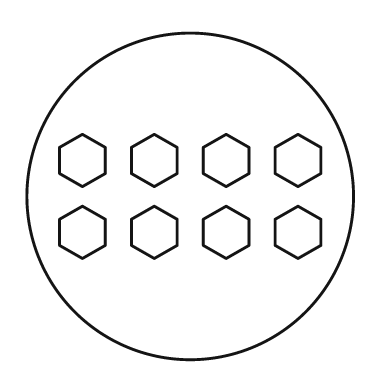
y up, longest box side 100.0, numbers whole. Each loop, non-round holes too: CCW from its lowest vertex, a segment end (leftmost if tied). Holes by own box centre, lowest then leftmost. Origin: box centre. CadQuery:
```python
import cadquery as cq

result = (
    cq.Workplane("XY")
    .moveTo(0.0, 0.0)
    .circle(50.0)
    .moveTo(-33.0, -19.0)
    .lineTo(-26.0, -15.0)
    .lineTo(-26.0, -7.0)
    .lineTo(-33.0, -3.0)
    .lineTo(-40.0, -7.0)
    .lineTo(-40.0, -15.0)
    .close()
    .moveTo(-11.0, -19.0)
    .lineTo(-4.0, -15.0)
    .lineTo(-4.0, -7.0)
    .lineTo(-11.0, -3.0)
    .lineTo(-18.0, -7.0)
    .lineTo(-18.0, -15.0)
    .close()
    .moveTo(11.0, -19.0)
    .lineTo(18.0, -15.0)
    .lineTo(18.0, -7.0)
    .lineTo(11.0, -3.0)
    .lineTo(4.0, -7.0)
    .lineTo(4.0, -15.0)
    .close()
    .moveTo(33.0, -19.0)
    .lineTo(40.0, -15.0)
    .lineTo(40.0, -7.0)
    .lineTo(33.0, -3.0)
    .lineTo(26.0, -7.0)
    .lineTo(26.0, -15.0)
    .close()
    .moveTo(-33.0, 3.0)
    .lineTo(-26.0, 7.0)
    .lineTo(-26.0, 15.0)
    .lineTo(-33.0, 19.0)
    .lineTo(-40.0, 15.0)
    .lineTo(-40.0, 7.0)
    .close()
    .moveTo(-11.0, 3.0)
    .lineTo(-4.0, 7.0)
    .lineTo(-4.0, 15.0)
    .lineTo(-11.0, 19.0)
    .lineTo(-18.0, 15.0)
    .lineTo(-18.0, 7.0)
    .close()
    .moveTo(11.0, 3.0)
    .lineTo(18.0, 7.0)
    .lineTo(18.0, 15.0)
    .lineTo(11.0, 19.0)
    .lineTo(4.0, 15.0)
    .lineTo(4.0, 7.0)
    .close()
    .moveTo(33.0, 3.0)
    .lineTo(40.0, 7.0)
    .lineTo(40.0, 15.0)
    .lineTo(33.0, 19.0)
    .lineTo(26.0, 15.0)
    .lineTo(26.0, 7.0)
    .close()
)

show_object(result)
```